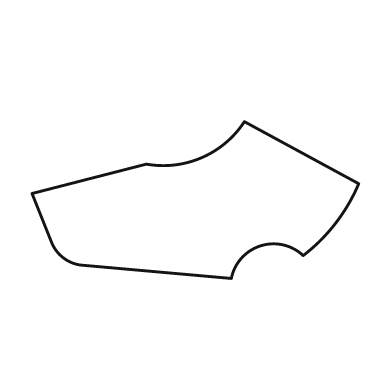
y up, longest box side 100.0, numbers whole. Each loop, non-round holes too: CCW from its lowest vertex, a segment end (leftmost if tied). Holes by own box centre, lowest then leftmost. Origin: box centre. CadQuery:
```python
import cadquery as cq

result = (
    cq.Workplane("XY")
    .moveTo(11.0, -24.0)
    .threePointArc((20.0, -14.0), (33.0, -17.0))
    .threePointArc((43.0, -7.0), (50.0, 5.0))
    .lineTo(15.0, 24.0)
    .threePointArc((2.0, 13.0), (-15.0, 11.0))
    .lineTo(-50.0, 2.0)
    .lineTo(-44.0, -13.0)
    .threePointArc((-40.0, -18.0), (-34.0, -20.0))
    .close()
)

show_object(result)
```